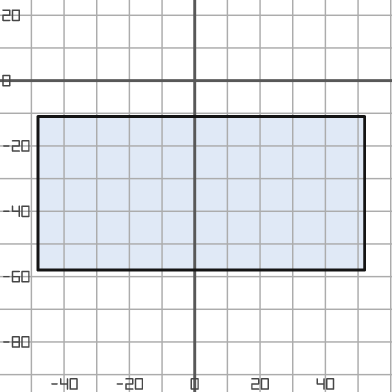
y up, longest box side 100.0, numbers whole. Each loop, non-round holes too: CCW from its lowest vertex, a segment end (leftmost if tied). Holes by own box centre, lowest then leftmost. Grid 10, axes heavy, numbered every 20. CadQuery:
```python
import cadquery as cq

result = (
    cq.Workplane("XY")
    .moveTo(-48.0, -58.0)
    .lineTo(52.0, -58.0)
    .lineTo(52.0, -11.0)
    .lineTo(-48.0, -11.0)
    .close()
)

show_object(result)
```